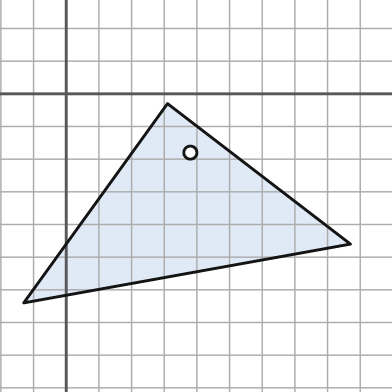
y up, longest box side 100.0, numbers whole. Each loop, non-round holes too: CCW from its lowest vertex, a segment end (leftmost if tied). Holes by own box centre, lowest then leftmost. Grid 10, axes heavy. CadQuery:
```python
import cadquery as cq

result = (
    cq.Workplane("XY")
    .moveTo(-13.0, -64.0)
    .lineTo(87.0, -46.0)
    .lineTo(31.0, -3.0)
    .close()
    .moveTo(38.0, -18.0)
    .circle(2.0)
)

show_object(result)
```